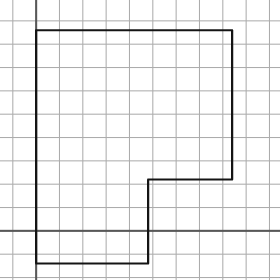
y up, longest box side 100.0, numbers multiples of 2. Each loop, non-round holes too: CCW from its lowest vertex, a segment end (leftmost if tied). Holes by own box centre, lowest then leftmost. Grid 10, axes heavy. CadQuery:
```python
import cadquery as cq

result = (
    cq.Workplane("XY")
    .moveTo(0.0, -14.0)
    .lineTo(48.0, -14.0)
    .lineTo(48.0, 22.0)
    .lineTo(84.0, 22.0)
    .lineTo(84.0, 86.0)
    .lineTo(0.0, 86.0)
    .close()
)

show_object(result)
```